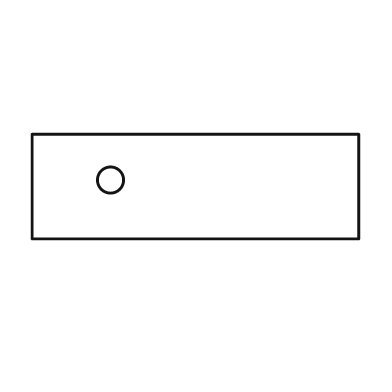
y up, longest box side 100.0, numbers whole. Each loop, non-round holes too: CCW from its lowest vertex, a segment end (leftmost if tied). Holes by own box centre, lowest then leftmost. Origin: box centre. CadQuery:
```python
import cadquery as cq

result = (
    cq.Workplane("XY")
    .moveTo(-50.0, -16.0)
    .lineTo(50.0, -16.0)
    .lineTo(50.0, 16.0)
    .lineTo(-50.0, 16.0)
    .close()
    .moveTo(-26.0, 2.0)
    .circle(4.0)
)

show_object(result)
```